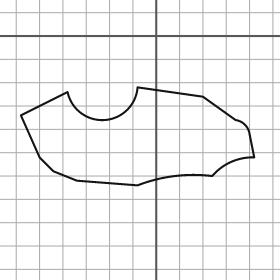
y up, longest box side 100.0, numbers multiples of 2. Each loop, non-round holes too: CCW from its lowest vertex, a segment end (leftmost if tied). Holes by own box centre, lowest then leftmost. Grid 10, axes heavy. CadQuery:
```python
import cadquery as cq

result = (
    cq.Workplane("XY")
    .moveTo(-8.0, -64.0)
    .threePointArc((8.0, -60.0), (24.0, -60.0))
    .threePointArc((32.0, -54.0), (42.0, -52.0))
    .lineTo(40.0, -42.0)
    .threePointArc((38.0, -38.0), (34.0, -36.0))
    .lineTo(20.0, -26.0)
    .lineTo(-8.0, -22.0)
    .threePointArc((-22.0, -36.0), (-38.0, -24.0))
    .lineTo(-58.0, -34.0)
    .lineTo(-50.0, -52.0)
    .lineTo(-44.0, -58.0)
    .lineTo(-34.0, -62.0)
    .close()
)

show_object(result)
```